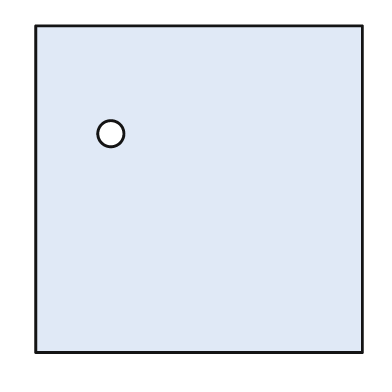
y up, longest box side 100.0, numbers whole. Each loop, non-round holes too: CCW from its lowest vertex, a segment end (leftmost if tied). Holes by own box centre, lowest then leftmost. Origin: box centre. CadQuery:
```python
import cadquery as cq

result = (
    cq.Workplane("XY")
    .moveTo(-50.0, -50.0)
    .lineTo(50.0, -50.0)
    .lineTo(50.0, 50.0)
    .lineTo(-50.0, 50.0)
    .close()
    .moveTo(-27.0, 17.0)
    .circle(4.0)
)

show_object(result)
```